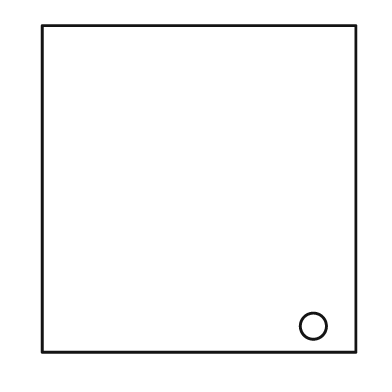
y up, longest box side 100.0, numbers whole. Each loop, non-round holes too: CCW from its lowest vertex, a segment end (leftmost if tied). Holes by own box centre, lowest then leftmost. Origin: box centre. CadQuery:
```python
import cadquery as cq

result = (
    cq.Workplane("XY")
    .moveTo(-48.0, -50.0)
    .lineTo(48.0, -50.0)
    .lineTo(48.0, 50.0)
    .lineTo(-48.0, 50.0)
    .close()
    .moveTo(35.0, -42.0)
    .circle(4.0)
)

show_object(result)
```